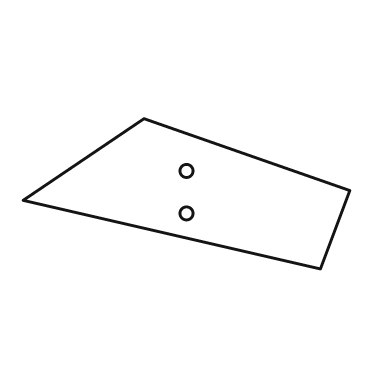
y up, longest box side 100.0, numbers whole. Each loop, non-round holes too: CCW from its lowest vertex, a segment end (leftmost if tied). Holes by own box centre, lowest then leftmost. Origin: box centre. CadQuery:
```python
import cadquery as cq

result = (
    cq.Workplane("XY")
    .moveTo(41.0, -23.0)
    .lineTo(50.0, 1.0)
    .lineTo(-13.0, 23.0)
    .lineTo(-50.0, -2.0)
    .close()
    .moveTo(0.0, -6.0)
    .circle(2.0)
    .moveTo(0.0, 7.0)
    .circle(2.0)
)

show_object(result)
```